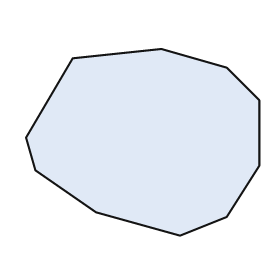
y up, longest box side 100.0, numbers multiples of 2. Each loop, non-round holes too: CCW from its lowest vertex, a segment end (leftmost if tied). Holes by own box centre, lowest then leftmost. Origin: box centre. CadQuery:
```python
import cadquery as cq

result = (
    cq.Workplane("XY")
    .moveTo(16.0, -40.0)
    .lineTo(36.0, -32.0)
    .lineTo(50.0, -10.0)
    .lineTo(50.0, 18.0)
    .lineTo(36.0, 32.0)
    .lineTo(8.0, 40.0)
    .lineTo(-30.0, 36.0)
    .lineTo(-50.0, 2.0)
    .lineTo(-46.0, -12.0)
    .lineTo(-20.0, -30.0)
    .close()
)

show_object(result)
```